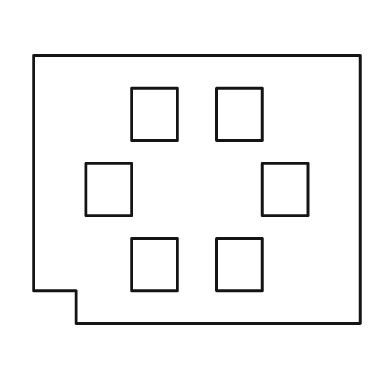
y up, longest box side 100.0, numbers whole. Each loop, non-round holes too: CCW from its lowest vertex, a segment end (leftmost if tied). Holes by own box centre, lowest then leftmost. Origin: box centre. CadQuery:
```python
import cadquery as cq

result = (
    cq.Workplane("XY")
    .moveTo(-37.0, -41.0)
    .lineTo(50.0, -41.0)
    .lineTo(50.0, 41.0)
    .lineTo(-50.0, 41.0)
    .lineTo(-50.0, -31.0)
    .lineTo(-37.0, -31.0)
    .close()
    .moveTo(-20.0, -31.0)
    .lineTo(-6.0, -31.0)
    .lineTo(-6.0, -15.0)
    .lineTo(-20.0, -15.0)
    .close()
    .moveTo(6.0, -31.0)
    .lineTo(20.0, -31.0)
    .lineTo(20.0, -15.0)
    .lineTo(6.0, -15.0)
    .close()
    .moveTo(-34.0, -8.0)
    .lineTo(-20.0, -8.0)
    .lineTo(-20.0, 8.0)
    .lineTo(-34.0, 8.0)
    .close()
    .moveTo(20.0, -8.0)
    .lineTo(34.0, -8.0)
    .lineTo(34.0, 8.0)
    .lineTo(20.0, 8.0)
    .close()
    .moveTo(-20.0, 15.0)
    .lineTo(-6.0, 15.0)
    .lineTo(-6.0, 31.0)
    .lineTo(-20.0, 31.0)
    .close()
    .moveTo(6.0, 15.0)
    .lineTo(20.0, 15.0)
    .lineTo(20.0, 31.0)
    .lineTo(6.0, 31.0)
    .close()
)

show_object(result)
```